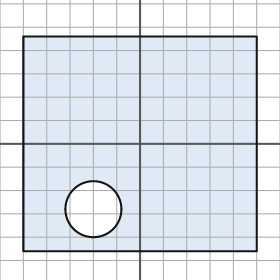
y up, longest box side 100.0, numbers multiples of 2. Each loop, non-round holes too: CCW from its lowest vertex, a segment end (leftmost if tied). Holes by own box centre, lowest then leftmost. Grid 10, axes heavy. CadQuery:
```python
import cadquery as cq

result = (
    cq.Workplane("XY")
    .moveTo(-50.0, -46.0)
    .lineTo(50.0, -46.0)
    .lineTo(50.0, 46.0)
    .lineTo(-50.0, 46.0)
    .close()
    .moveTo(-20.0, -28.0)
    .circle(12.0)
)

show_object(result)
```